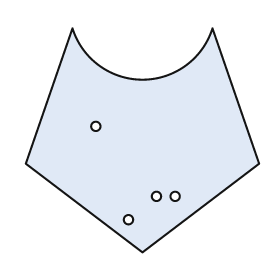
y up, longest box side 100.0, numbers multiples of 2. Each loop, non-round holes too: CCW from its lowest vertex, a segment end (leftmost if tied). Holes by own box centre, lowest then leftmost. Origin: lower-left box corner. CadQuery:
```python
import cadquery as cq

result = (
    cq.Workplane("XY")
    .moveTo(50.0, 0.0)
    .lineTo(100.0, 38.0)
    .lineTo(80.0, 96.0)
    .threePointArc((50.0, 74.0), (20.0, 96.0))
    .lineTo(0.0, 38.0)
    .close()
    .moveTo(44.0, 14.0)
    .circle(2.0)
    .moveTo(56.0, 24.0)
    .circle(2.0)
    .moveTo(64.0, 24.0)
    .circle(2.0)
    .moveTo(30.0, 54.0)
    .circle(2.0)
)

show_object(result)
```